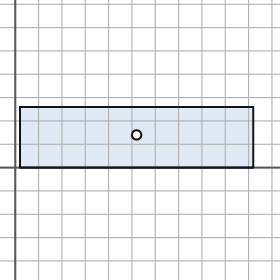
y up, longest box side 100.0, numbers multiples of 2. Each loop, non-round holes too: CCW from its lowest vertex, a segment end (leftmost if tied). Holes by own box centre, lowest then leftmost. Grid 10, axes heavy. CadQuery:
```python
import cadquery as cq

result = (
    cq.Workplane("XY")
    .moveTo(2.0, 0.0)
    .lineTo(102.0, 0.0)
    .lineTo(102.0, 26.0)
    .lineTo(2.0, 26.0)
    .close()
    .moveTo(52.0, 14.0)
    .circle(2.0)
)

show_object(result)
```